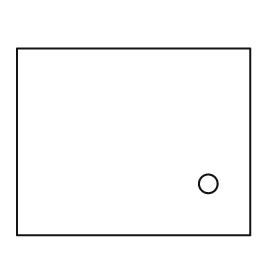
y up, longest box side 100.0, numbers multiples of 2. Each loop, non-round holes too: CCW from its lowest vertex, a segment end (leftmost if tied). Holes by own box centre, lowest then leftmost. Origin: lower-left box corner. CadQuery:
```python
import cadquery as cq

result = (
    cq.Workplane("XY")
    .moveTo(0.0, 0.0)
    .lineTo(100.0, 0.0)
    .lineTo(100.0, 80.0)
    .lineTo(0.0, 80.0)
    .close()
    .moveTo(82.0, 22.0)
    .circle(4.0)
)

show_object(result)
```